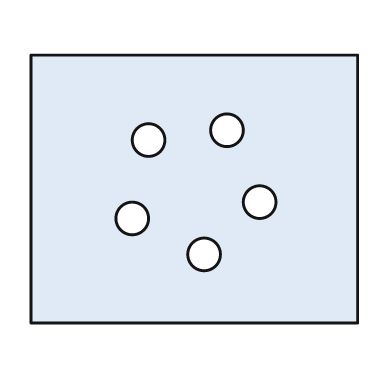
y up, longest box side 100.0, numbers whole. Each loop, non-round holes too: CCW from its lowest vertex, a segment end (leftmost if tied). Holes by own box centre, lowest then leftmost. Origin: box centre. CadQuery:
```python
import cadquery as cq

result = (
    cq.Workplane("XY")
    .moveTo(-50.0, -41.0)
    .lineTo(50.0, -41.0)
    .lineTo(50.0, 41.0)
    .lineTo(-50.0, 41.0)
    .close()
    .moveTo(3.0, -20.0)
    .circle(5.0)
    .moveTo(-19.0, -9.0)
    .circle(5.0)
    .moveTo(20.0, -4.0)
    .circle(5.0)
    .moveTo(-14.0, 15.0)
    .circle(5.0)
    .moveTo(10.0, 18.0)
    .circle(5.0)
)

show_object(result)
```